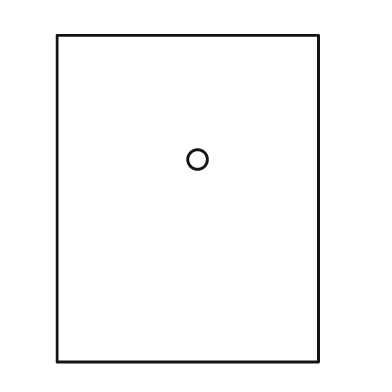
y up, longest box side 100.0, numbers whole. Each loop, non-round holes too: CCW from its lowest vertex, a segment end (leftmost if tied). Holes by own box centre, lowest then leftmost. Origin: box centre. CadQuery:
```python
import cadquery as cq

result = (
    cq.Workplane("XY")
    .moveTo(-40.0, -50.0)
    .lineTo(40.0, -50.0)
    .lineTo(40.0, 50.0)
    .lineTo(-40.0, 50.0)
    .close()
    .moveTo(3.0, 12.0)
    .circle(3.0)
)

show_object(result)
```